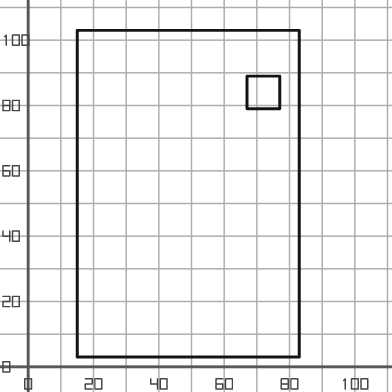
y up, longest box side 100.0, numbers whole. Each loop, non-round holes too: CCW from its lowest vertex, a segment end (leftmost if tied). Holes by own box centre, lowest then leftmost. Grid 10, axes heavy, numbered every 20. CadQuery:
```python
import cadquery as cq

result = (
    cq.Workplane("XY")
    .moveTo(15.0, 3.0)
    .lineTo(83.0, 3.0)
    .lineTo(83.0, 103.0)
    .lineTo(15.0, 103.0)
    .close()
    .moveTo(67.0, 79.0)
    .lineTo(77.0, 79.0)
    .lineTo(77.0, 89.0)
    .lineTo(67.0, 89.0)
    .close()
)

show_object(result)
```